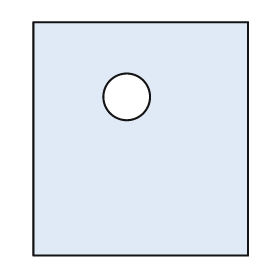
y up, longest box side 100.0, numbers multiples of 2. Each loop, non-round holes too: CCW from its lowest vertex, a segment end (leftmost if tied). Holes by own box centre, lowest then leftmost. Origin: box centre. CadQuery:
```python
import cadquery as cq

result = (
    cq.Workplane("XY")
    .moveTo(-46.0, -50.0)
    .lineTo(46.0, -50.0)
    .lineTo(46.0, 50.0)
    .lineTo(-46.0, 50.0)
    .close()
    .moveTo(-6.0, 18.0)
    .circle(10.0)
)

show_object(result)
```